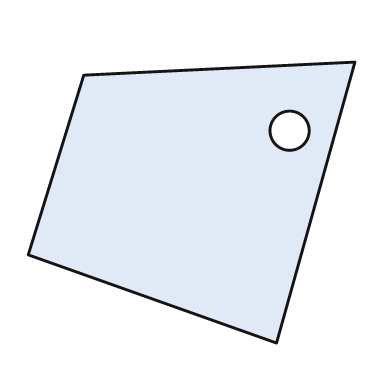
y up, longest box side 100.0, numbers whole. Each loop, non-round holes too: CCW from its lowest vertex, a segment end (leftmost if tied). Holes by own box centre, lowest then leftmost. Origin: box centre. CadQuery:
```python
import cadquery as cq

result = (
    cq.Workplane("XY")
    .moveTo(26.0, -43.0)
    .lineTo(50.0, 43.0)
    .lineTo(-33.0, 39.0)
    .lineTo(-50.0, -16.0)
    .close()
    .moveTo(30.0, 22.0)
    .circle(6.0)
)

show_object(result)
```